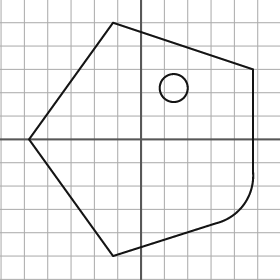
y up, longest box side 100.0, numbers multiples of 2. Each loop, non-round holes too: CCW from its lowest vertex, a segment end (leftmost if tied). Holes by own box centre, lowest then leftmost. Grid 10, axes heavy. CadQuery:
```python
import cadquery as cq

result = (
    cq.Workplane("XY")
    .moveTo(-12.0, -50.0)
    .lineTo(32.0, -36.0)
    .threePointArc((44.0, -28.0), (48.0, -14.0))
    .lineTo(48.0, 30.0)
    .lineTo(-12.0, 50.0)
    .lineTo(-48.0, 0.0)
    .close()
    .moveTo(14.0, 22.0)
    .circle(6.0)
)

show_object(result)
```